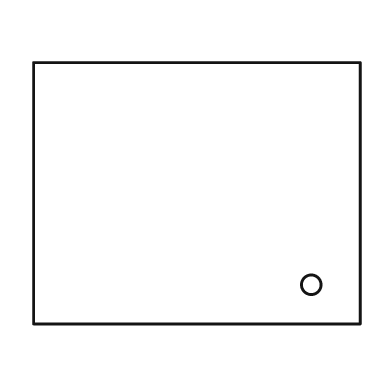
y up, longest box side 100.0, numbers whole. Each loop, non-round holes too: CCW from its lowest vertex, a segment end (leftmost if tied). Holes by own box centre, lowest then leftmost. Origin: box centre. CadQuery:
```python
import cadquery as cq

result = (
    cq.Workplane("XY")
    .moveTo(-50.0, -40.0)
    .lineTo(50.0, -40.0)
    .lineTo(50.0, 40.0)
    .lineTo(-50.0, 40.0)
    .close()
    .moveTo(35.0, -28.0)
    .circle(3.0)
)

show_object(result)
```